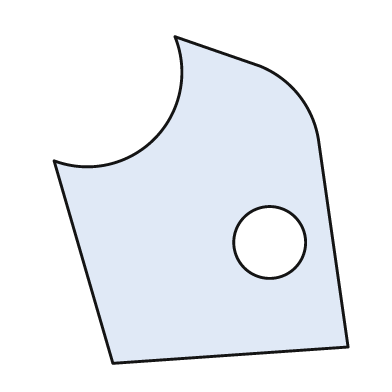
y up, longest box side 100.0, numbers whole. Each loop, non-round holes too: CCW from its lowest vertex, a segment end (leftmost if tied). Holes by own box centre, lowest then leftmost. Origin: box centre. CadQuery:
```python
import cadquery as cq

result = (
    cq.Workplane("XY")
    .moveTo(-27.0, -50.0)
    .lineTo(45.0, -45.0)
    .lineTo(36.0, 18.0)
    .threePointArc((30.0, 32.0), (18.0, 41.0))
    .lineTo(-8.0, 50.0)
    .threePointArc((-14.0, 19.0), (-45.0, 12.0))
    .close()
    .moveTo(21.0, -13.0)
    .circle(11.0)
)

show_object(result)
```